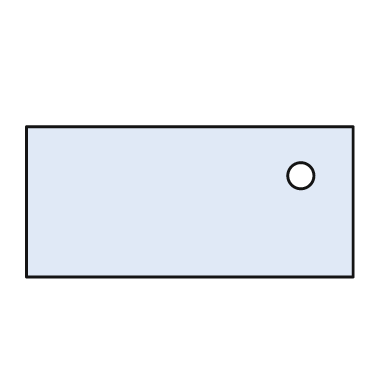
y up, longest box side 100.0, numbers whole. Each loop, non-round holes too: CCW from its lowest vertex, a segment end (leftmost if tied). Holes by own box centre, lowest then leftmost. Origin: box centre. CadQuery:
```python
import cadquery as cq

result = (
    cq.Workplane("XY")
    .moveTo(-50.0, -23.0)
    .lineTo(50.0, -23.0)
    .lineTo(50.0, 23.0)
    .lineTo(-50.0, 23.0)
    .close()
    .moveTo(34.0, 8.0)
    .circle(4.0)
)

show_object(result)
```